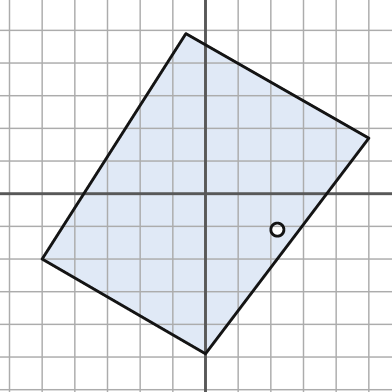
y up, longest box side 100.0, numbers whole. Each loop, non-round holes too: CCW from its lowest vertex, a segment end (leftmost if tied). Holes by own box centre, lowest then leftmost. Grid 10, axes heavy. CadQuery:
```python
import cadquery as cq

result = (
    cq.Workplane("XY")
    .moveTo(0.0, -49.0)
    .lineTo(50.0, 17.0)
    .lineTo(-6.0, 49.0)
    .lineTo(-50.0, -20.0)
    .close()
    .moveTo(22.0, -11.0)
    .circle(2.0)
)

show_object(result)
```